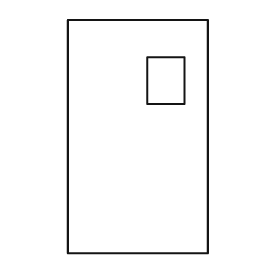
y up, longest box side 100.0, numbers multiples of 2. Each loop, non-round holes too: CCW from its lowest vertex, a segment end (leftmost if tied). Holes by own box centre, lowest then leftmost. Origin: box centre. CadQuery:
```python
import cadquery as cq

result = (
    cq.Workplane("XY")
    .moveTo(-30.0, -50.0)
    .lineTo(30.0, -50.0)
    .lineTo(30.0, 50.0)
    .lineTo(-30.0, 50.0)
    .close()
    .moveTo(4.0, 14.0)
    .lineTo(20.0, 14.0)
    .lineTo(20.0, 34.0)
    .lineTo(4.0, 34.0)
    .close()
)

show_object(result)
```